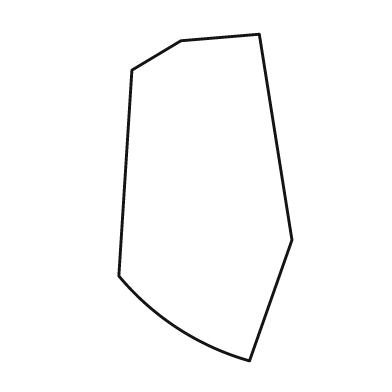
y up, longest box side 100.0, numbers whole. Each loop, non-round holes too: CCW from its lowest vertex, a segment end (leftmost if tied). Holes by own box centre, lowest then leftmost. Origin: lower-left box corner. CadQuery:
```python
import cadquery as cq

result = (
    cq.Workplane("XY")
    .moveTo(40.0, 0.0)
    .lineTo(53.0, 37.0)
    .lineTo(43.0, 100.0)
    .lineTo(19.0, 98.0)
    .lineTo(4.0, 89.0)
    .lineTo(0.0, 26.0)
    .threePointArc((18.0, 10.0), (40.0, 0.0))
    .close()
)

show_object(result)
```